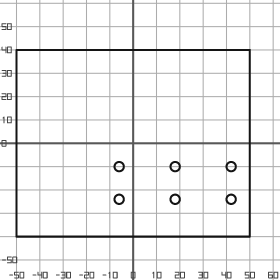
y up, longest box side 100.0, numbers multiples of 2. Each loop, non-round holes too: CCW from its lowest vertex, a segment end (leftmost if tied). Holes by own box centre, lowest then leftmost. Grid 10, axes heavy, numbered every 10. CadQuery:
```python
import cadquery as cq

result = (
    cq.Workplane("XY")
    .moveTo(-50.0, -40.0)
    .lineTo(50.0, -40.0)
    .lineTo(50.0, 40.0)
    .lineTo(-50.0, 40.0)
    .close()
    .moveTo(-6.0, -24.0)
    .circle(2.0)
    .moveTo(18.0, -24.0)
    .circle(2.0)
    .moveTo(42.0, -24.0)
    .circle(2.0)
    .moveTo(-6.0, -10.0)
    .circle(2.0)
    .moveTo(18.0, -10.0)
    .circle(2.0)
    .moveTo(42.0, -10.0)
    .circle(2.0)
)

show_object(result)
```